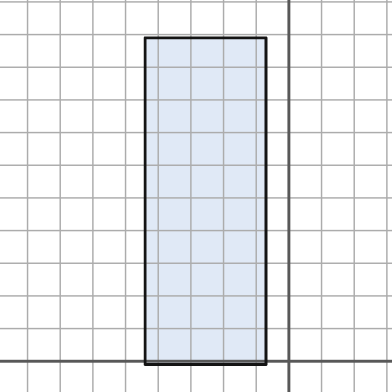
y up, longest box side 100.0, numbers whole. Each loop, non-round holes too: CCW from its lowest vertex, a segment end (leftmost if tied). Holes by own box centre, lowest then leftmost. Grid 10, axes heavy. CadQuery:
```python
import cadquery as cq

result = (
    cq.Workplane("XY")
    .moveTo(-44.0, -1.0)
    .lineTo(-7.0, -1.0)
    .lineTo(-7.0, 99.0)
    .lineTo(-44.0, 99.0)
    .close()
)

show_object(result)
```